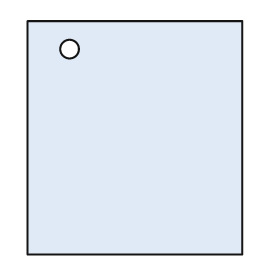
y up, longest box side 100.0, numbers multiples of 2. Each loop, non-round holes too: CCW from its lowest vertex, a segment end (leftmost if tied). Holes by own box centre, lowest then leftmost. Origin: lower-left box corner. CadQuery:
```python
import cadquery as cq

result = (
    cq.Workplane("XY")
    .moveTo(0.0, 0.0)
    .lineTo(92.0, 0.0)
    .lineTo(92.0, 100.0)
    .lineTo(0.0, 100.0)
    .close()
    .moveTo(18.0, 88.0)
    .circle(4.0)
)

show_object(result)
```